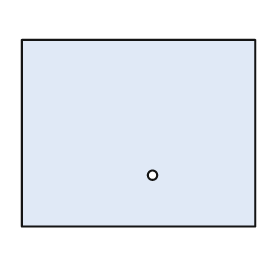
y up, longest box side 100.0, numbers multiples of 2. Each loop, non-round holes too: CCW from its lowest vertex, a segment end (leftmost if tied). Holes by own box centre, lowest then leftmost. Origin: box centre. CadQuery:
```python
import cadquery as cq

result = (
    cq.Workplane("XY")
    .moveTo(-50.0, -40.0)
    .lineTo(50.0, -40.0)
    .lineTo(50.0, 40.0)
    .lineTo(-50.0, 40.0)
    .close()
    .moveTo(6.0, -18.0)
    .circle(2.0)
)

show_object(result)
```